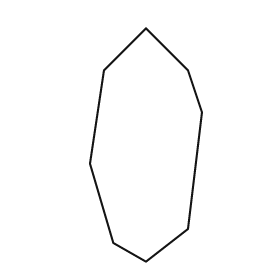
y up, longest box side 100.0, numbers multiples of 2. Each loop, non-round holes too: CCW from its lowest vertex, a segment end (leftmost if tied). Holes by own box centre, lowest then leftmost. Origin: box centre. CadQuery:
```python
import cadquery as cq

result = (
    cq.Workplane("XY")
    .moveTo(0.0, -50.0)
    .lineTo(18.0, -36.0)
    .lineTo(24.0, 14.0)
    .lineTo(18.0, 32.0)
    .lineTo(0.0, 50.0)
    .lineTo(-18.0, 32.0)
    .lineTo(-24.0, -8.0)
    .lineTo(-14.0, -42.0)
    .close()
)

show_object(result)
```